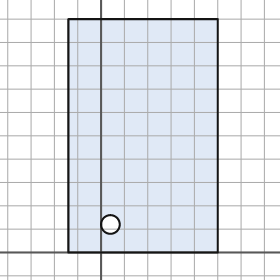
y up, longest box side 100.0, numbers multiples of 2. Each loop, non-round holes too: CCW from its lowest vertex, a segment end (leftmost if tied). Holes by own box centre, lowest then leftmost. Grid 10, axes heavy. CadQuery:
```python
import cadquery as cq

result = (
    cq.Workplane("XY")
    .moveTo(-14.0, 0.0)
    .lineTo(50.0, 0.0)
    .lineTo(50.0, 100.0)
    .lineTo(-14.0, 100.0)
    .close()
    .moveTo(4.0, 12.0)
    .circle(4.0)
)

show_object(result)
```